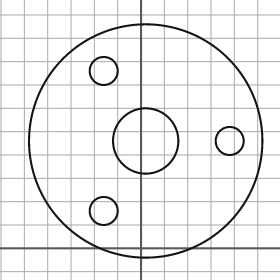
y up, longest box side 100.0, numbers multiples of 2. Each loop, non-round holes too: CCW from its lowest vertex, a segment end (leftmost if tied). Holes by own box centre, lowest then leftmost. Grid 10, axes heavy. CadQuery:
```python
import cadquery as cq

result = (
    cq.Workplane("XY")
    .moveTo(2.0, 46.0)
    .circle(50.0)
    .moveTo(-16.0, 16.0)
    .circle(6.0)
    .moveTo(2.0, 46.0)
    .circle(14.0)
    .moveTo(38.0, 46.0)
    .circle(6.0)
    .moveTo(-16.0, 76.0)
    .circle(6.0)
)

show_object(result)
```